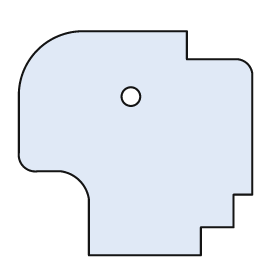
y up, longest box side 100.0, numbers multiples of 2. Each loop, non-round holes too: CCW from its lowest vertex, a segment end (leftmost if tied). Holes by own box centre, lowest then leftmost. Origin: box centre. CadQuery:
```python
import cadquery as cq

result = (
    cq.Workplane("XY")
    .moveTo(-20.0, -48.0)
    .lineTo(28.0, -48.0)
    .lineTo(28.0, -36.0)
    .lineTo(42.0, -36.0)
    .lineTo(42.0, -22.0)
    .lineTo(50.0, -22.0)
    .lineTo(50.0, 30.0)
    .threePointArc((48.0, 34.0), (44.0, 36.0))
    .lineTo(22.0, 36.0)
    .lineTo(22.0, 48.0)
    .lineTo(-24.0, 48.0)
    .threePointArc((-42.0, 40.0), (-50.0, 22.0))
    .lineTo(-50.0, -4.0)
    .threePointArc((-48.0, -10.0), (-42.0, -12.0))
    .lineTo(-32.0, -12.0)
    .threePointArc((-24.0, -16.0), (-20.0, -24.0))
    .close()
    .moveTo(-2.0, 20.0)
    .circle(4.0)
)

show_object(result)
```